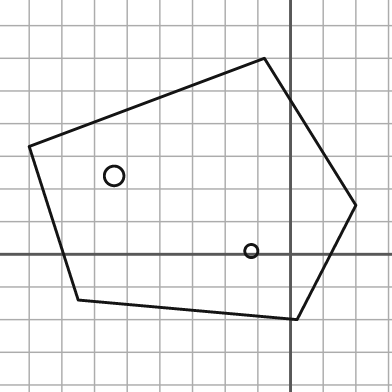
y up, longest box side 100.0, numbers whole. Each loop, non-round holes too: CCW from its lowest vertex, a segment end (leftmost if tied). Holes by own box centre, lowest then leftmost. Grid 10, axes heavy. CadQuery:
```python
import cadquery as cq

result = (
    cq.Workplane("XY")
    .moveTo(2.0, -20.0)
    .lineTo(20.0, 15.0)
    .lineTo(-8.0, 60.0)
    .lineTo(-80.0, 33.0)
    .lineTo(-65.0, -14.0)
    .close()
    .moveTo(-12.0, 1.0)
    .circle(2.0)
    .moveTo(-54.0, 24.0)
    .circle(3.0)
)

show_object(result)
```